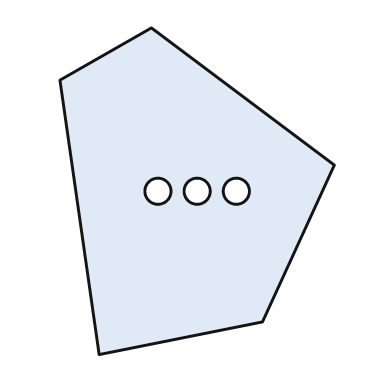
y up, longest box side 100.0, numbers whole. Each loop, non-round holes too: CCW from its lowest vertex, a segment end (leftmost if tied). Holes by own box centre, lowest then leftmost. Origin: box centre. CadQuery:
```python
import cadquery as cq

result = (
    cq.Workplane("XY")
    .moveTo(-30.0, -50.0)
    .lineTo(20.0, -40.0)
    .lineTo(42.0, 8.0)
    .lineTo(-14.0, 50.0)
    .lineTo(-42.0, 34.0)
    .close()
    .moveTo(-12.0, 0.0)
    .circle(4.0)
    .moveTo(0.0, 0.0)
    .circle(4.0)
    .moveTo(12.0, 0.0)
    .circle(4.0)
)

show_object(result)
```